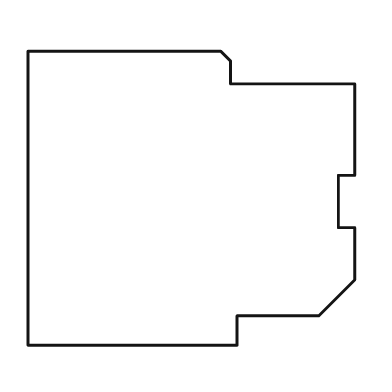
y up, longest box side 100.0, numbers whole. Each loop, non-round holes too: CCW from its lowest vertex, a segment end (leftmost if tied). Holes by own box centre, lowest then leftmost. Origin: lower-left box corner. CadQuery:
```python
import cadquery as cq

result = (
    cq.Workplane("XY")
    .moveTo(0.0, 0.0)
    .lineTo(64.0, 0.0)
    .lineTo(64.0, 9.0)
    .lineTo(89.0, 9.0)
    .lineTo(100.0, 20.0)
    .lineTo(100.0, 36.0)
    .lineTo(95.0, 36.0)
    .lineTo(95.0, 52.0)
    .lineTo(100.0, 52.0)
    .lineTo(100.0, 80.0)
    .lineTo(62.0, 80.0)
    .lineTo(62.0, 87.0)
    .lineTo(59.0, 90.0)
    .lineTo(0.0, 90.0)
    .close()
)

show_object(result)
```